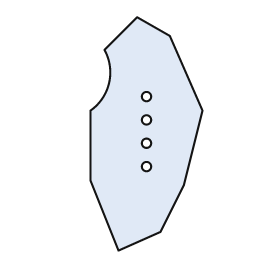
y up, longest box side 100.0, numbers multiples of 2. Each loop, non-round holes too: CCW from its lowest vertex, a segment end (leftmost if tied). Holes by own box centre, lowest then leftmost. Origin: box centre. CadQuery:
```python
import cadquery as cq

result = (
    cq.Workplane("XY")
    .moveTo(-12.0, -50.0)
    .lineTo(6.0, -42.0)
    .lineTo(16.0, -22.0)
    .lineTo(24.0, 10.0)
    .lineTo(10.0, 42.0)
    .lineTo(-4.0, 50.0)
    .lineTo(-18.0, 36.0)
    .threePointArc((-16.0, 22.0), (-24.0, 10.0))
    .lineTo(-24.0, -20.0)
    .close()
    .moveTo(0.0, -14.0)
    .circle(2.0)
    .moveTo(0.0, -4.0)
    .circle(2.0)
    .moveTo(0.0, 6.0)
    .circle(2.0)
    .moveTo(0.0, 16.0)
    .circle(2.0)
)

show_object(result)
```